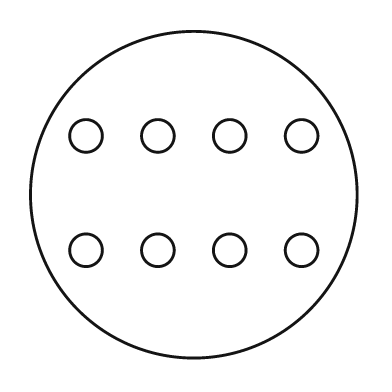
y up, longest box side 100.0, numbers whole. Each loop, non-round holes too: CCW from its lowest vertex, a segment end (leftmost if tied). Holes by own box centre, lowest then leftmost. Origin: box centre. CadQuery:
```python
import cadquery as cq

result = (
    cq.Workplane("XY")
    .moveTo(0.0, 0.0)
    .circle(50.0)
    .moveTo(-33.0, -17.0)
    .circle(5.0)
    .moveTo(-11.0, -17.0)
    .circle(5.0)
    .moveTo(11.0, -17.0)
    .circle(5.0)
    .moveTo(33.0, -17.0)
    .circle(5.0)
    .moveTo(-33.0, 18.0)
    .circle(5.0)
    .moveTo(-11.0, 18.0)
    .circle(5.0)
    .moveTo(11.0, 18.0)
    .circle(5.0)
    .moveTo(33.0, 18.0)
    .circle(5.0)
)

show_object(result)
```